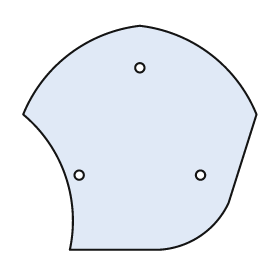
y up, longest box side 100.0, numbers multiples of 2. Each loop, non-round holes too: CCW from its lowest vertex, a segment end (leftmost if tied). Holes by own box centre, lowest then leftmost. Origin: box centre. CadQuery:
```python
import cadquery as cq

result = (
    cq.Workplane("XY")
    .moveTo(-30.0, -48.0)
    .lineTo(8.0, -48.0)
    .threePointArc((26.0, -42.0), (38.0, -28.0))
    .lineTo(50.0, 10.0)
    .threePointArc((30.0, 36.0), (0.0, 48.0))
    .threePointArc((-30.0, 36.0), (-50.0, 10.0))
    .threePointArc((-32.0, -16.0), (-30.0, -48.0))
    .close()
    .moveTo(-26.0, -16.0)
    .circle(2.0)
    .moveTo(26.0, -16.0)
    .circle(2.0)
    .moveTo(0.0, 30.0)
    .circle(2.0)
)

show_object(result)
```